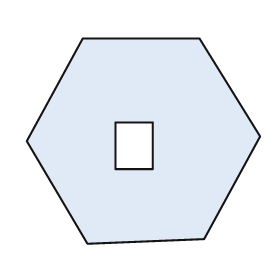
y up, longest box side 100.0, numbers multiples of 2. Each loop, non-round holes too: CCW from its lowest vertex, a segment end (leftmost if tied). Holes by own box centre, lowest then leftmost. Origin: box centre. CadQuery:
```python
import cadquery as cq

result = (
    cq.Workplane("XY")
    .moveTo(-24.0, -44.0)
    .lineTo(26.0, -42.0)
    .lineTo(50.0, 2.0)
    .lineTo(24.0, 44.0)
    .lineTo(-26.0, 44.0)
    .lineTo(-50.0, 0.0)
    .close()
    .moveTo(-12.0, -12.0)
    .lineTo(4.0, -12.0)
    .lineTo(4.0, 8.0)
    .lineTo(-12.0, 8.0)
    .close()
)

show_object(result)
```